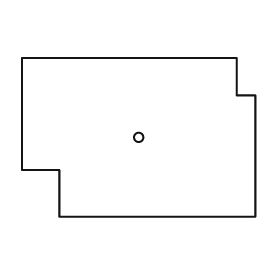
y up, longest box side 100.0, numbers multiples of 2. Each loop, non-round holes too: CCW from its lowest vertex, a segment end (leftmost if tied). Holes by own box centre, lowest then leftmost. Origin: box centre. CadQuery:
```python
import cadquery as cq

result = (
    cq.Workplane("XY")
    .moveTo(-34.0, -34.0)
    .lineTo(50.0, -34.0)
    .lineTo(50.0, 18.0)
    .lineTo(42.0, 18.0)
    .lineTo(42.0, 34.0)
    .lineTo(-50.0, 34.0)
    .lineTo(-50.0, -14.0)
    .lineTo(-34.0, -14.0)
    .close()
    .moveTo(0.0, 0.0)
    .circle(2.0)
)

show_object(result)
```